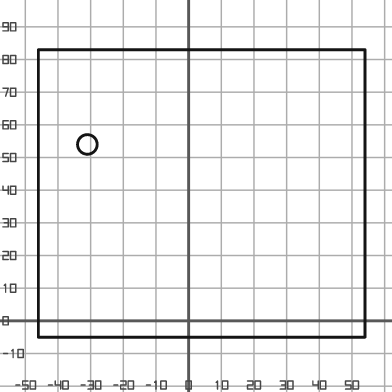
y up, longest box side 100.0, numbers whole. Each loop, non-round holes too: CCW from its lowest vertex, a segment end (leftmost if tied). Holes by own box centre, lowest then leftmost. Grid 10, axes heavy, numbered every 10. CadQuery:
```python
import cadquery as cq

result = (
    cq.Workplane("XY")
    .moveTo(-46.0, -5.0)
    .lineTo(54.0, -5.0)
    .lineTo(54.0, 83.0)
    .lineTo(-46.0, 83.0)
    .close()
    .moveTo(-31.0, 54.0)
    .circle(3.0)
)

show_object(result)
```